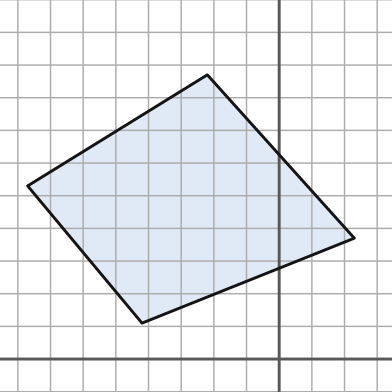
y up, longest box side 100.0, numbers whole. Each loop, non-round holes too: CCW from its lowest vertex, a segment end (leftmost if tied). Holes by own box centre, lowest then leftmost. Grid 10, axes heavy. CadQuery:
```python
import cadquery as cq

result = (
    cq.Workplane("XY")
    .moveTo(-42.0, 11.0)
    .lineTo(23.0, 37.0)
    .lineTo(-22.0, 87.0)
    .lineTo(-77.0, 53.0)
    .close()
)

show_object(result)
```